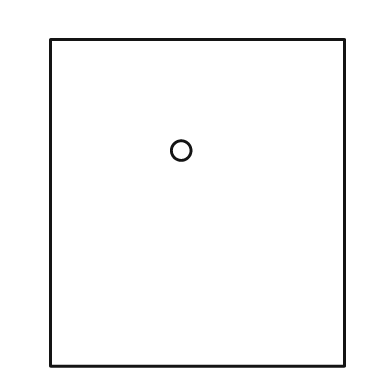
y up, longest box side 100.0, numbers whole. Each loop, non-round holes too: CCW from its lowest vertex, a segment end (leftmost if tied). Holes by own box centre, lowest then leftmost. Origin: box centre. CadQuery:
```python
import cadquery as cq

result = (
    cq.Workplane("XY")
    .moveTo(-45.0, -50.0)
    .lineTo(45.0, -50.0)
    .lineTo(45.0, 50.0)
    .lineTo(-45.0, 50.0)
    .close()
    .moveTo(-5.0, 16.0)
    .circle(3.0)
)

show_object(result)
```